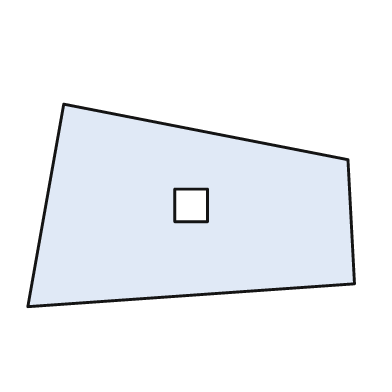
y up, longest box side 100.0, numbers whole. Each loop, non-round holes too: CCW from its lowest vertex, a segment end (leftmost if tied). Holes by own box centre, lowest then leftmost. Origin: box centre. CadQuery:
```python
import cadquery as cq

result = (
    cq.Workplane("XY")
    .moveTo(-50.0, -31.0)
    .lineTo(50.0, -24.0)
    .lineTo(48.0, 14.0)
    .lineTo(-39.0, 31.0)
    .close()
    .moveTo(-5.0, -5.0)
    .lineTo(5.0, -5.0)
    .lineTo(5.0, 5.0)
    .lineTo(-5.0, 5.0)
    .close()
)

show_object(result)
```